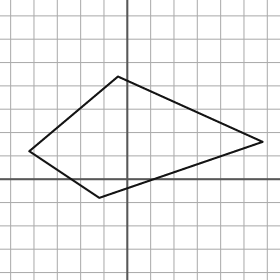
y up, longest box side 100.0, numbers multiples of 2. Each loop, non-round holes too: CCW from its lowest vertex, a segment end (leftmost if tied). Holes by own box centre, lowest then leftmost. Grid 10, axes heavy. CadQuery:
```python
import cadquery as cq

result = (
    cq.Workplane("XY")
    .moveTo(-12.0, -8.0)
    .lineTo(58.0, 16.0)
    .lineTo(-4.0, 44.0)
    .lineTo(-42.0, 12.0)
    .close()
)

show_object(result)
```